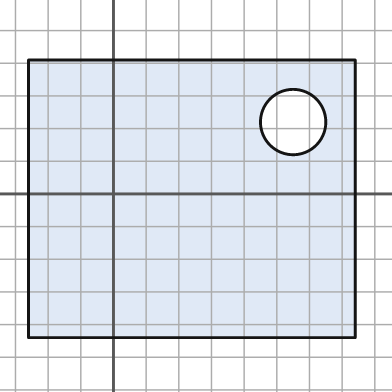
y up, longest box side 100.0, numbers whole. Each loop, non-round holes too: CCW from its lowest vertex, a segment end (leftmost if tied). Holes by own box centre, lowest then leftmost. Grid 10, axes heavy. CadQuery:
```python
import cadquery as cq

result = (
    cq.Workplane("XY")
    .moveTo(-26.0, -44.0)
    .lineTo(74.0, -44.0)
    .lineTo(74.0, 41.0)
    .lineTo(-26.0, 41.0)
    .close()
    .moveTo(55.0, 22.0)
    .circle(10.0)
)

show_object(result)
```